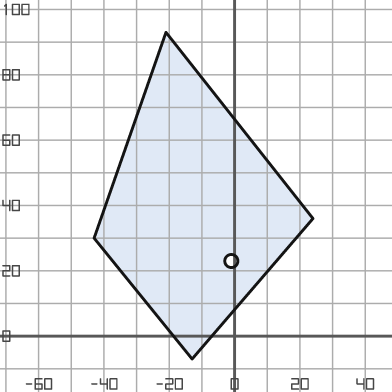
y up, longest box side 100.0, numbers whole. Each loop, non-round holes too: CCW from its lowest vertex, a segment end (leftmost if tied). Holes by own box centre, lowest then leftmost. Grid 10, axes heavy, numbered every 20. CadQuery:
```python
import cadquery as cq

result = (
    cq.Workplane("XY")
    .moveTo(-13.0, -7.0)
    .lineTo(24.0, 36.0)
    .lineTo(-21.0, 93.0)
    .lineTo(-43.0, 30.0)
    .close()
    .moveTo(-1.0, 23.0)
    .circle(2.0)
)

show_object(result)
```